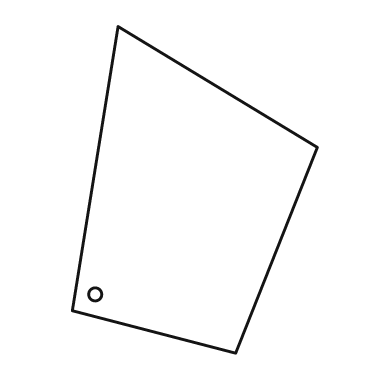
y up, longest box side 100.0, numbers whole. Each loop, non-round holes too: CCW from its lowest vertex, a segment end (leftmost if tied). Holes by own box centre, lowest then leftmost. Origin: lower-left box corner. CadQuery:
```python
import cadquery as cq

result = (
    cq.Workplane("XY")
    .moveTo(50.0, 0.0)
    .lineTo(75.0, 63.0)
    .lineTo(14.0, 100.0)
    .lineTo(0.0, 13.0)
    .close()
    .moveTo(7.0, 18.0)
    .circle(2.0)
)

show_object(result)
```